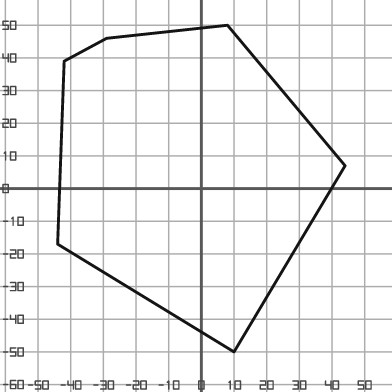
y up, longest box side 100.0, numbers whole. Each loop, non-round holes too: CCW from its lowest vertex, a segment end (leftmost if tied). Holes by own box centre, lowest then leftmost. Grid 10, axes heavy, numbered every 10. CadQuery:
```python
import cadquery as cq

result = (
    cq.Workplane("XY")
    .moveTo(10.0, -50.0)
    .lineTo(44.0, 7.0)
    .lineTo(8.0, 50.0)
    .lineTo(-29.0, 46.0)
    .lineTo(-42.0, 39.0)
    .lineTo(-44.0, -17.0)
    .close()
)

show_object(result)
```